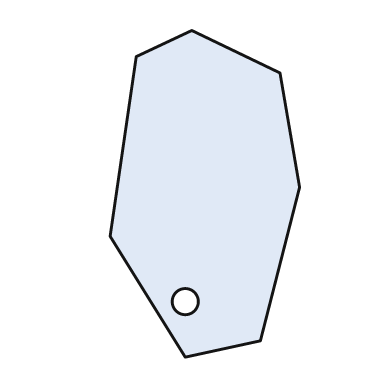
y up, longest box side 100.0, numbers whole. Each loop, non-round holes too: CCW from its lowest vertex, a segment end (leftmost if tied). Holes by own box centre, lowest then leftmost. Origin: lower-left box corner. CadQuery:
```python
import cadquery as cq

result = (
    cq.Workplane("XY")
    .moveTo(23.0, 0.0)
    .lineTo(46.0, 5.0)
    .lineTo(58.0, 52.0)
    .lineTo(52.0, 87.0)
    .lineTo(25.0, 100.0)
    .lineTo(8.0, 92.0)
    .lineTo(0.0, 37.0)
    .close()
    .moveTo(23.0, 17.0)
    .circle(4.0)
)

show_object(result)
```